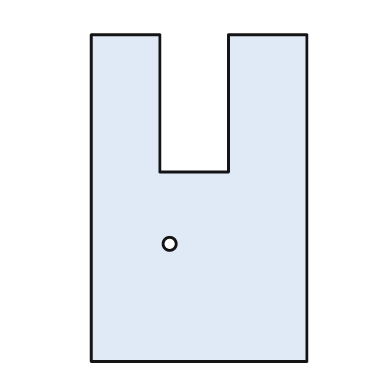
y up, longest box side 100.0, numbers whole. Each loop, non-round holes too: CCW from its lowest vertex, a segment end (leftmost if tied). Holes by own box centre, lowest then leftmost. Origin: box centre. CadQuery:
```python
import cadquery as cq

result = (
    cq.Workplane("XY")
    .moveTo(-33.0, -50.0)
    .lineTo(33.0, -50.0)
    .lineTo(33.0, 50.0)
    .lineTo(9.0, 50.0)
    .lineTo(9.0, 8.0)
    .lineTo(-12.0, 8.0)
    .lineTo(-12.0, 50.0)
    .lineTo(-33.0, 50.0)
    .close()
    .moveTo(-9.0, -14.0)
    .circle(2.0)
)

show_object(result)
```